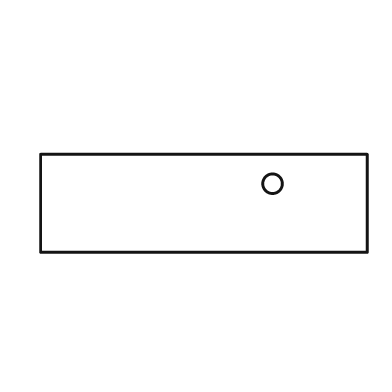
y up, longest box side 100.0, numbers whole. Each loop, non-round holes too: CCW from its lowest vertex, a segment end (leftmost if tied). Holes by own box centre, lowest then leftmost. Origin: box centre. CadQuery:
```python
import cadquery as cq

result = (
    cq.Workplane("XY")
    .moveTo(-50.0, -15.0)
    .lineTo(50.0, -15.0)
    .lineTo(50.0, 15.0)
    .lineTo(-50.0, 15.0)
    .close()
    .moveTo(21.0, 6.0)
    .circle(3.0)
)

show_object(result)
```